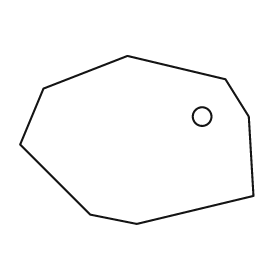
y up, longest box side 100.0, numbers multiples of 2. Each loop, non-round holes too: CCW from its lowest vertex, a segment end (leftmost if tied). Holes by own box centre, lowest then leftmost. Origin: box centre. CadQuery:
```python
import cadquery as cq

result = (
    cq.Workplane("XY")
    .moveTo(0.0, -36.0)
    .lineTo(50.0, -24.0)
    .lineTo(48.0, 10.0)
    .lineTo(38.0, 26.0)
    .lineTo(-4.0, 36.0)
    .lineTo(-40.0, 22.0)
    .lineTo(-50.0, -2.0)
    .lineTo(-20.0, -32.0)
    .close()
    .moveTo(28.0, 10.0)
    .circle(4.0)
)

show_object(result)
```